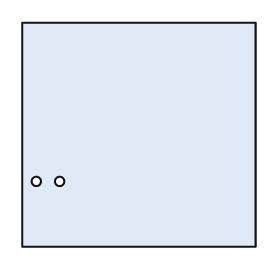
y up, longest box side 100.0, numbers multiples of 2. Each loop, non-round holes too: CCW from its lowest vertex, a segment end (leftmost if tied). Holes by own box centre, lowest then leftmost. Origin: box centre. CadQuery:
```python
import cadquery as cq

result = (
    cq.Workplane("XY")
    .moveTo(-50.0, -48.0)
    .lineTo(50.0, -48.0)
    .lineTo(50.0, 48.0)
    .lineTo(-50.0, 48.0)
    .close()
    .moveTo(-44.0, -20.0)
    .circle(2.0)
    .moveTo(-34.0, -20.0)
    .circle(2.0)
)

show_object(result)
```